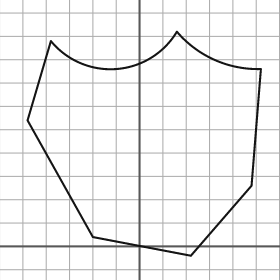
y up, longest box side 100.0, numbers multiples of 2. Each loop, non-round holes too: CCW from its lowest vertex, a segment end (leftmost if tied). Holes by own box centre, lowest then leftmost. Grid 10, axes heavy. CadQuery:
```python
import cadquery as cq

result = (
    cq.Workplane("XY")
    .moveTo(22.0, -4.0)
    .lineTo(48.0, 26.0)
    .lineTo(52.0, 76.0)
    .threePointArc((32.0, 80.0), (16.0, 92.0))
    .threePointArc((-10.0, 76.0), (-38.0, 88.0))
    .lineTo(-48.0, 54.0)
    .lineTo(-20.0, 4.0)
    .close()
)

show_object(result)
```